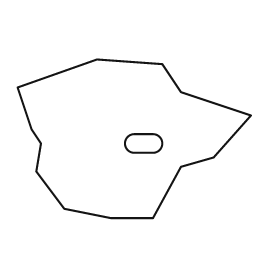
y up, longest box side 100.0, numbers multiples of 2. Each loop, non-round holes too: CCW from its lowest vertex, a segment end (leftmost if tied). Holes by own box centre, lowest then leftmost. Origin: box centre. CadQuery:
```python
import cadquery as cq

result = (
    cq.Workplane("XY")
    .moveTo(-10.0, -34.0)
    .lineTo(8.0, -34.0)
    .lineTo(20.0, -12.0)
    .lineTo(34.0, -8.0)
    .lineTo(50.0, 10.0)
    .lineTo(20.0, 20.0)
    .lineTo(12.0, 32.0)
    .lineTo(-16.0, 34.0)
    .lineTo(-50.0, 22.0)
    .lineTo(-44.0, 4.0)
    .lineTo(-40.0, -2.0)
    .lineTo(-42.0, -14.0)
    .lineTo(-30.0, -30.0)
    .close()
    .moveTo(0.0, -6.0)
    .lineTo(8.0, -6.0)
    .threePointArc((12.0, -2.0), (8.0, 2.0))
    .lineTo(0.0, 2.0)
    .threePointArc((-4.0, -2.0), (0.0, -6.0))
    .close()
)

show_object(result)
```